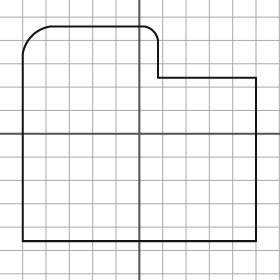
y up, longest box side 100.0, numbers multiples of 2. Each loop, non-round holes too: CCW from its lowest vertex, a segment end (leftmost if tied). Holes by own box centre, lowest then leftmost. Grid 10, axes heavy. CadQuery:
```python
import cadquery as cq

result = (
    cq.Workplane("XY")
    .moveTo(-50.0, -46.0)
    .lineTo(50.0, -46.0)
    .lineTo(50.0, 24.0)
    .lineTo(8.0, 24.0)
    .lineTo(8.0, 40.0)
    .threePointArc((6.0, 44.0), (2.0, 46.0))
    .lineTo(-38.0, 46.0)
    .threePointArc((-46.0, 42.0), (-50.0, 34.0))
    .close()
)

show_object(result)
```